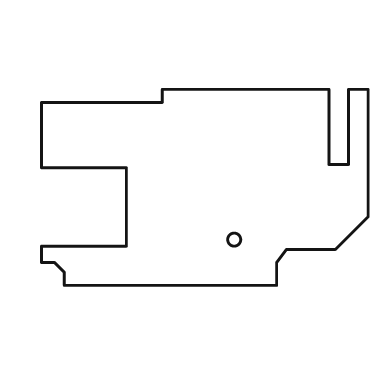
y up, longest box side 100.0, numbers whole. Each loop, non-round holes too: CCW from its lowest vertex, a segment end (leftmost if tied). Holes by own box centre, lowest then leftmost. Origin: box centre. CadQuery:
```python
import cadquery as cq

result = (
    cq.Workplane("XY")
    .moveTo(-43.0, -30.0)
    .lineTo(22.0, -30.0)
    .lineTo(22.0, -23.0)
    .lineTo(25.0, -19.0)
    .lineTo(40.0, -19.0)
    .lineTo(50.0, -9.0)
    .lineTo(50.0, 30.0)
    .lineTo(44.0, 30.0)
    .lineTo(44.0, 7.0)
    .lineTo(38.0, 7.0)
    .lineTo(38.0, 30.0)
    .lineTo(-13.0, 30.0)
    .lineTo(-13.0, 26.0)
    .lineTo(-50.0, 26.0)
    .lineTo(-50.0, 6.0)
    .lineTo(-24.0, 6.0)
    .lineTo(-24.0, -18.0)
    .lineTo(-50.0, -18.0)
    .lineTo(-50.0, -23.0)
    .lineTo(-46.0, -23.0)
    .lineTo(-43.0, -26.0)
    .close()
    .moveTo(9.0, -16.0)
    .circle(2.0)
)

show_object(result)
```